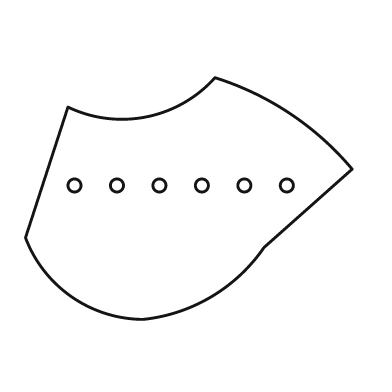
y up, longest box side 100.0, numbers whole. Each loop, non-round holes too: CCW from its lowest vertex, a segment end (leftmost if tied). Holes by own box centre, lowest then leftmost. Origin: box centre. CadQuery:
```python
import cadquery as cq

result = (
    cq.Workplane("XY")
    .moveTo(-14.0, -37.0)
    .threePointArc((7.0, -30.0), (23.0, -15.0))
    .lineTo(50.0, 9.0)
    .threePointArc((31.0, 26.0), (8.0, 37.0))
    .threePointArc((-13.0, 25.0), (-37.0, 28.0))
    .lineTo(-50.0, -12.0)
    .threePointArc((-36.0, -30.0), (-14.0, -37.0))
    .close()
    .moveTo(-35.0, 4.0)
    .circle(2.0)
    .moveTo(-22.0, 4.0)
    .circle(2.0)
    .moveTo(-9.0, 4.0)
    .circle(2.0)
    .moveTo(4.0, 4.0)
    .circle(2.0)
    .moveTo(17.0, 4.0)
    .circle(2.0)
    .moveTo(30.0, 4.0)
    .circle(2.0)
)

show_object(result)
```